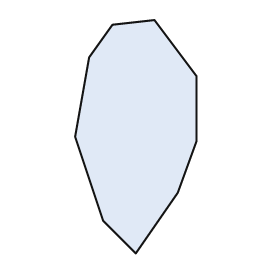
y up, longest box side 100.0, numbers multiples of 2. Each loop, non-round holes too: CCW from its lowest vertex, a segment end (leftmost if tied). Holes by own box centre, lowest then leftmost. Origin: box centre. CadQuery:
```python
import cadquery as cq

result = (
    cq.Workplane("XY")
    .moveTo(0.0, -50.0)
    .lineTo(18.0, -24.0)
    .lineTo(26.0, -2.0)
    .lineTo(26.0, 26.0)
    .lineTo(8.0, 50.0)
    .lineTo(-10.0, 48.0)
    .lineTo(-20.0, 34.0)
    .lineTo(-26.0, 0.0)
    .lineTo(-14.0, -36.0)
    .close()
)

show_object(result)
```